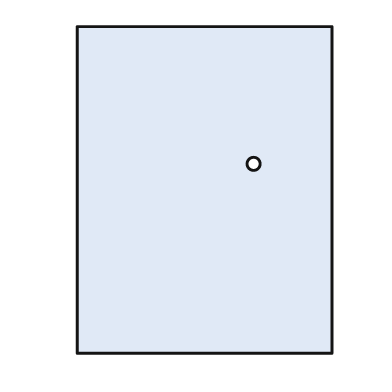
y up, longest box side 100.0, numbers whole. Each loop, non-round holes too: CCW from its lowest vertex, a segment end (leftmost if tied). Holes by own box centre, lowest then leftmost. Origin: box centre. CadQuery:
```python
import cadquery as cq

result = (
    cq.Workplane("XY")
    .moveTo(-39.0, -50.0)
    .lineTo(39.0, -50.0)
    .lineTo(39.0, 50.0)
    .lineTo(-39.0, 50.0)
    .close()
    .moveTo(15.0, 8.0)
    .circle(2.0)
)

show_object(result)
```